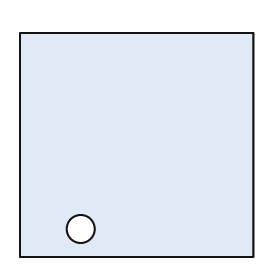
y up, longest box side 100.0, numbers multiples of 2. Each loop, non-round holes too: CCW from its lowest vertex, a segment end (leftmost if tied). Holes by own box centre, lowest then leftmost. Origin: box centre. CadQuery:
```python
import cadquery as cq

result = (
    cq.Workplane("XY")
    .moveTo(-50.0, -48.0)
    .lineTo(50.0, -48.0)
    .lineTo(50.0, 48.0)
    .lineTo(-50.0, 48.0)
    .close()
    .moveTo(-24.0, -36.0)
    .circle(6.0)
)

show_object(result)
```